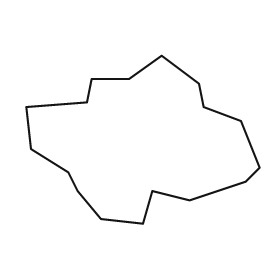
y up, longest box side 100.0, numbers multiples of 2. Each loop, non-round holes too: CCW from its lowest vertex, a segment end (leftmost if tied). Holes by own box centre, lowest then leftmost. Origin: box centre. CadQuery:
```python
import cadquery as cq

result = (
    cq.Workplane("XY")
    .moveTo(0.0, -36.0)
    .lineTo(4.0, -22.0)
    .lineTo(20.0, -26.0)
    .lineTo(44.0, -18.0)
    .lineTo(50.0, -12.0)
    .lineTo(42.0, 8.0)
    .lineTo(26.0, 14.0)
    .lineTo(24.0, 24.0)
    .lineTo(8.0, 36.0)
    .lineTo(-6.0, 26.0)
    .lineTo(-22.0, 26.0)
    .lineTo(-24.0, 16.0)
    .lineTo(-50.0, 14.0)
    .lineTo(-48.0, -4.0)
    .lineTo(-32.0, -14.0)
    .lineTo(-28.0, -22.0)
    .lineTo(-18.0, -34.0)
    .close()
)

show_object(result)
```